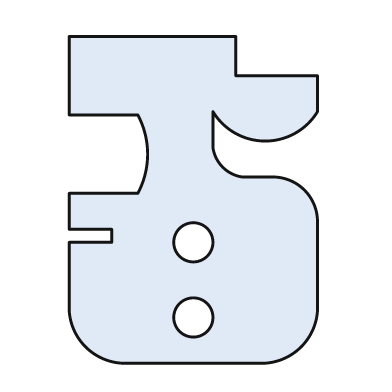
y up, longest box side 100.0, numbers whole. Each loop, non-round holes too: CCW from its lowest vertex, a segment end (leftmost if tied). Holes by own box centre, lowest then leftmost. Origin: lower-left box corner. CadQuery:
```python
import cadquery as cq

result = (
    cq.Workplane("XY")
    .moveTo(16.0, 0.0)
    .lineTo(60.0, 0.0)
    .threePointArc((71.0, 5.0), (76.0, 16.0))
    .lineTo(76.0, 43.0)
    .threePointArc((72.0, 53.0), (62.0, 57.0))
    .lineTo(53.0, 57.0)
    .threePointArc((47.0, 60.0), (44.0, 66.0))
    .lineTo(44.0, 77.0)
    .threePointArc((60.0, 68.0), (76.0, 77.0))
    .lineTo(76.0, 88.0)
    .lineTo(51.0, 88.0)
    .lineTo(51.0, 100.0)
    .lineTo(0.0, 100.0)
    .lineTo(0.0, 76.0)
    .lineTo(21.0, 76.0)
    .threePointArc((24.0, 64.0), (21.0, 52.0))
    .lineTo(0.0, 52.0)
    .lineTo(0.0, 41.0)
    .lineTo(13.0, 41.0)
    .lineTo(13.0, 37.0)
    .lineTo(0.0, 37.0)
    .lineTo(0.0, 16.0)
    .threePointArc((5.0, 5.0), (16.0, 0.0))
    .close()
    .moveTo(38.0, 14.0)
    .circle(6.0)
    .moveTo(38.0, 37.0)
    .circle(6.0)
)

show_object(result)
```